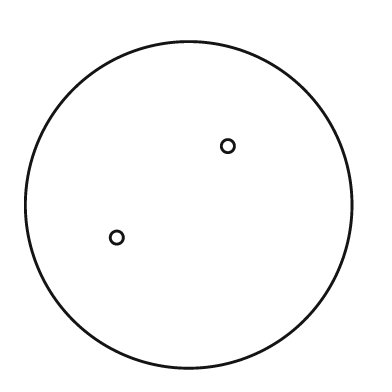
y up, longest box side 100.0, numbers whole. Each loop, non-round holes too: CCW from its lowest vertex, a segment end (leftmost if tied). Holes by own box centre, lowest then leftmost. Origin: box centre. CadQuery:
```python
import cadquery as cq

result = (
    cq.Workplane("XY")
    .moveTo(0.0, 0.0)
    .circle(50.0)
    .moveTo(-22.0, -10.0)
    .circle(2.0)
    .moveTo(12.0, 18.0)
    .circle(2.0)
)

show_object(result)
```